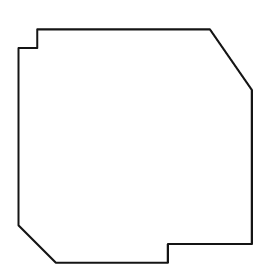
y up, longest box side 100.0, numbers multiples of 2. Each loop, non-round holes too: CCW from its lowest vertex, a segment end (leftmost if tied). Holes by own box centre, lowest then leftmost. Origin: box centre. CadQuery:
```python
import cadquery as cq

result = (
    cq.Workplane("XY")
    .moveTo(-34.0, -50.0)
    .lineTo(14.0, -50.0)
    .lineTo(14.0, -42.0)
    .lineTo(50.0, -42.0)
    .lineTo(50.0, 24.0)
    .lineTo(32.0, 50.0)
    .lineTo(-42.0, 50.0)
    .lineTo(-42.0, 42.0)
    .lineTo(-50.0, 42.0)
    .lineTo(-50.0, -34.0)
    .close()
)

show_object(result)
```